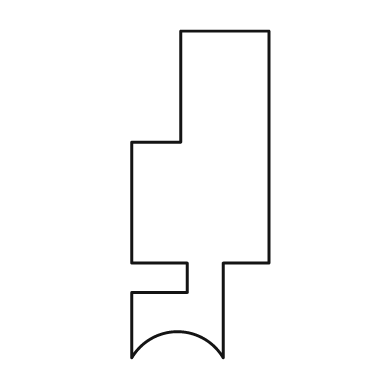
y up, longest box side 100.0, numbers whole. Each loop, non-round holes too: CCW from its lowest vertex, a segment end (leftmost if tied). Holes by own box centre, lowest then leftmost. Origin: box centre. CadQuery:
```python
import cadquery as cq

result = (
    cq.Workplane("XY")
    .moveTo(-21.0, -50.0)
    .threePointArc((-7.0, -42.0), (7.0, -50.0))
    .lineTo(7.0, -21.0)
    .lineTo(21.0, -21.0)
    .lineTo(21.0, 50.0)
    .lineTo(-6.0, 50.0)
    .lineTo(-6.0, 16.0)
    .lineTo(-21.0, 16.0)
    .lineTo(-21.0, -21.0)
    .lineTo(-4.0, -21.0)
    .lineTo(-4.0, -30.0)
    .lineTo(-21.0, -30.0)
    .close()
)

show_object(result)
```